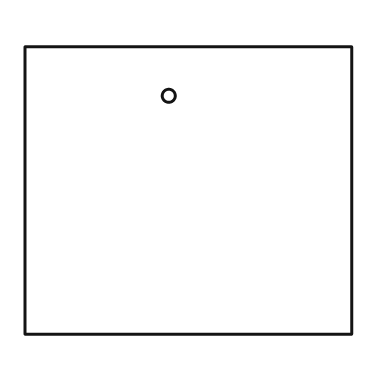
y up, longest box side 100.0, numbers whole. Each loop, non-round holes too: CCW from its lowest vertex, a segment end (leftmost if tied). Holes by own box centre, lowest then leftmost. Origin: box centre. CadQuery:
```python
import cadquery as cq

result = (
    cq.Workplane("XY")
    .moveTo(-50.0, -44.0)
    .lineTo(50.0, -44.0)
    .lineTo(50.0, 44.0)
    .lineTo(-50.0, 44.0)
    .close()
    .moveTo(-6.0, 29.0)
    .circle(2.0)
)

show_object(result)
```